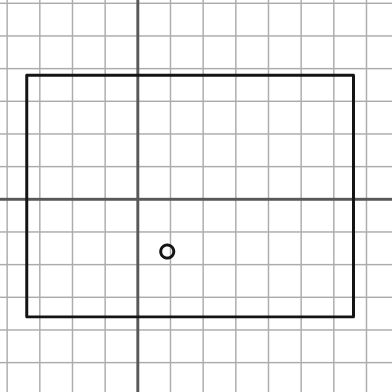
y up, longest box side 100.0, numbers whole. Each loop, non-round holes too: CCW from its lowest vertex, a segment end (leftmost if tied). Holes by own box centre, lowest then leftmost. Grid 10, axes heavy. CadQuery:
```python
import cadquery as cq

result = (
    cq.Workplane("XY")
    .moveTo(-34.0, -36.0)
    .lineTo(66.0, -36.0)
    .lineTo(66.0, 38.0)
    .lineTo(-34.0, 38.0)
    .close()
    .moveTo(9.0, -16.0)
    .circle(2.0)
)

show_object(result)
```